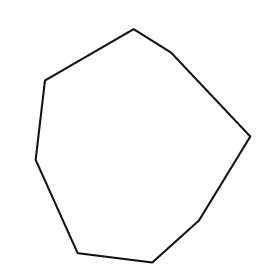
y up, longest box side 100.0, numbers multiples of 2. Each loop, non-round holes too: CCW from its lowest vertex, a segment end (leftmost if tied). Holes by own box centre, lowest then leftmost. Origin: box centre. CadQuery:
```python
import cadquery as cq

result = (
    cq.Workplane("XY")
    .moveTo(4.0, -50.0)
    .lineTo(24.0, -32.0)
    .lineTo(46.0, 4.0)
    .lineTo(12.0, 40.0)
    .lineTo(-4.0, 50.0)
    .lineTo(-42.0, 28.0)
    .lineTo(-46.0, -6.0)
    .lineTo(-28.0, -46.0)
    .close()
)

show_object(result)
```